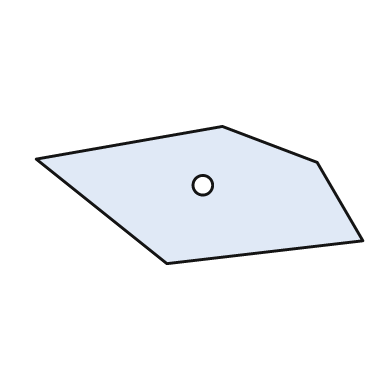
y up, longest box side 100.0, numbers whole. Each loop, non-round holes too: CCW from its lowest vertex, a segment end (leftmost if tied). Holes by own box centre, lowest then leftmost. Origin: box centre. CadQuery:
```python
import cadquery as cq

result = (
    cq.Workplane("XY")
    .moveTo(-10.0, -21.0)
    .lineTo(50.0, -14.0)
    .lineTo(36.0, 10.0)
    .lineTo(7.0, 21.0)
    .lineTo(-50.0, 11.0)
    .close()
    .moveTo(1.0, 3.0)
    .circle(3.0)
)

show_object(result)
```